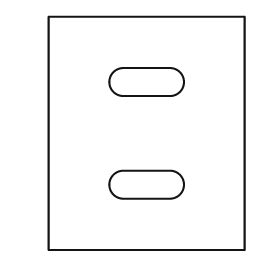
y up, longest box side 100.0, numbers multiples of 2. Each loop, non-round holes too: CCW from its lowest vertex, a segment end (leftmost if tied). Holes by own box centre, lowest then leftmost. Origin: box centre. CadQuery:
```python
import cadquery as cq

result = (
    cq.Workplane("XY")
    .moveTo(-42.0, -50.0)
    .lineTo(42.0, -50.0)
    .lineTo(42.0, 50.0)
    .lineTo(-42.0, 50.0)
    .close()
    .moveTo(-10.0, -28.0)
    .lineTo(10.0, -28.0)
    .threePointArc((16.0, -22.0), (10.0, -16.0))
    .lineTo(-10.0, -16.0)
    .threePointArc((-16.0, -22.0), (-10.0, -28.0))
    .close()
    .moveTo(-10.0, 16.0)
    .lineTo(10.0, 16.0)
    .threePointArc((16.0, 22.0), (10.0, 28.0))
    .lineTo(-10.0, 28.0)
    .threePointArc((-16.0, 22.0), (-10.0, 16.0))
    .close()
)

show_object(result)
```